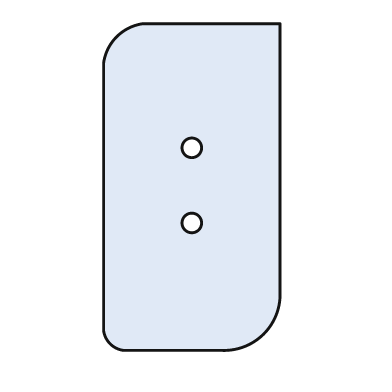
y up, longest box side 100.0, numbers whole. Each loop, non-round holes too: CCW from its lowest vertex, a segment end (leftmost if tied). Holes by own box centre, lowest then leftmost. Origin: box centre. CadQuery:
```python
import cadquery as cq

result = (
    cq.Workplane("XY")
    .moveTo(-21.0, -50.0)
    .lineTo(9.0, -50.0)
    .threePointArc((22.0, -45.0), (27.0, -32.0))
    .lineTo(27.0, 50.0)
    .lineTo(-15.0, 50.0)
    .threePointArc((-23.0, 46.0), (-27.0, 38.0))
    .lineTo(-27.0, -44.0)
    .threePointArc((-25.0, -48.0), (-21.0, -50.0))
    .close()
    .moveTo(0.0, -11.0)
    .circle(3.0)
    .moveTo(0.0, 12.0)
    .circle(3.0)
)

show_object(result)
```